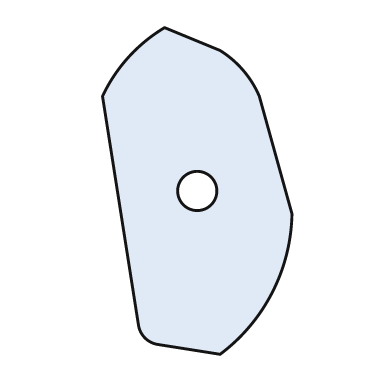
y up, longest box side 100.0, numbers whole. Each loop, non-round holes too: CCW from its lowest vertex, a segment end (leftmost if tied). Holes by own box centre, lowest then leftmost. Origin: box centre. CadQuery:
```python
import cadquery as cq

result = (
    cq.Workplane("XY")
    .moveTo(7.0, -50.0)
    .threePointArc((23.0, -31.0), (29.0, -7.0))
    .lineTo(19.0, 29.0)
    .threePointArc((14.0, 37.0), (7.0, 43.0))
    .lineTo(-10.0, 50.0)
    .threePointArc((-21.0, 41.0), (-29.0, 29.0))
    .lineTo(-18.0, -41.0)
    .threePointArc((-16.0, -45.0), (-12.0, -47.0))
    .close()
    .moveTo(0.0, 0.0)
    .circle(6.0)
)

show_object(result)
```